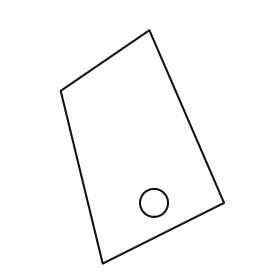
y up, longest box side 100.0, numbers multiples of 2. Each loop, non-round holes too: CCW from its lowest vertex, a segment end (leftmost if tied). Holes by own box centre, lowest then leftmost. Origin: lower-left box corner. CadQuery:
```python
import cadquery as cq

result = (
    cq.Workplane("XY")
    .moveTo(18.0, 0.0)
    .lineTo(70.0, 26.0)
    .lineTo(38.0, 100.0)
    .lineTo(0.0, 74.0)
    .close()
    .moveTo(40.0, 26.0)
    .circle(6.0)
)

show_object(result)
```